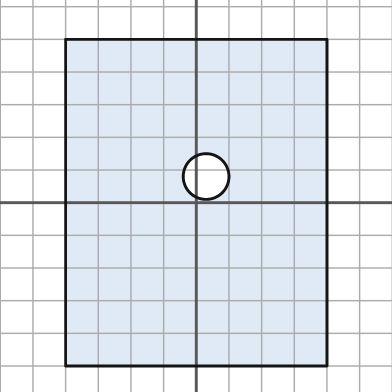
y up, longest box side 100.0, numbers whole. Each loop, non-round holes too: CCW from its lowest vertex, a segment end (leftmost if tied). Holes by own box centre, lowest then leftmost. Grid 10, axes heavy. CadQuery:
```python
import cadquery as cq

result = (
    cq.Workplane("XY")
    .moveTo(-40.0, -50.0)
    .lineTo(40.0, -50.0)
    .lineTo(40.0, 50.0)
    .lineTo(-40.0, 50.0)
    .close()
    .moveTo(3.0, 8.0)
    .circle(7.0)
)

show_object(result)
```